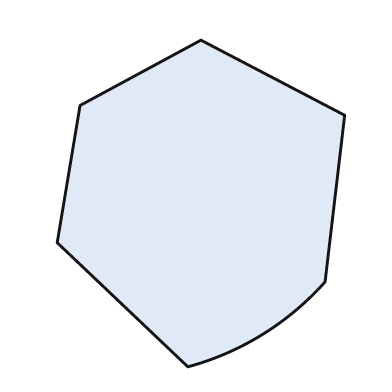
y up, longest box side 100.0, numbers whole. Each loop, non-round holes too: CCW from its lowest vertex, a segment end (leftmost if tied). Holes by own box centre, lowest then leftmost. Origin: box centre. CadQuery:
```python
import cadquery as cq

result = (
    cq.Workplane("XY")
    .moveTo(-4.0, -50.0)
    .threePointArc((19.0, -40.0), (38.0, -24.0))
    .lineTo(44.0, 27.0)
    .lineTo(0.0, 50.0)
    .lineTo(-37.0, 30.0)
    .lineTo(-44.0, -12.0)
    .close()
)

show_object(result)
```